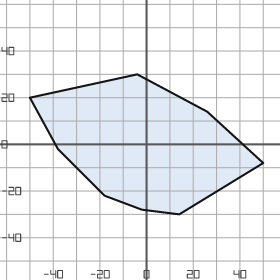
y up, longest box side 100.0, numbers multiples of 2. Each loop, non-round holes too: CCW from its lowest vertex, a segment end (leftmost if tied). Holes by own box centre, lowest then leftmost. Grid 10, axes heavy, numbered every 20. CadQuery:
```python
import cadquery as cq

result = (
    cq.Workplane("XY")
    .moveTo(14.0, -30.0)
    .lineTo(50.0, -8.0)
    .lineTo(26.0, 14.0)
    .lineTo(-4.0, 30.0)
    .lineTo(-50.0, 20.0)
    .lineTo(-38.0, -2.0)
    .lineTo(-18.0, -22.0)
    .lineTo(-2.0, -28.0)
    .close()
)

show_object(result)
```